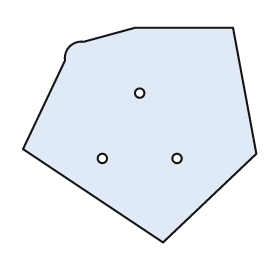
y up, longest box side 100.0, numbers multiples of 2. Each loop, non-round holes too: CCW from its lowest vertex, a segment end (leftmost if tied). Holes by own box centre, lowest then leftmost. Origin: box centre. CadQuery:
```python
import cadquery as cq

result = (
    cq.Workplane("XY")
    .moveTo(10.0, -46.0)
    .lineTo(50.0, -8.0)
    .lineTo(40.0, 46.0)
    .lineTo(-2.0, 46.0)
    .lineTo(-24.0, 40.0)
    .threePointArc((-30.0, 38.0), (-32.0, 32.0))
    .lineTo(-50.0, -6.0)
    .close()
    .moveTo(-16.0, -10.0)
    .circle(2.0)
    .moveTo(16.0, -10.0)
    .circle(2.0)
    .moveTo(0.0, 18.0)
    .circle(2.0)
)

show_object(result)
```